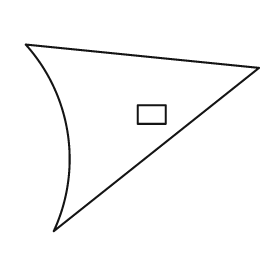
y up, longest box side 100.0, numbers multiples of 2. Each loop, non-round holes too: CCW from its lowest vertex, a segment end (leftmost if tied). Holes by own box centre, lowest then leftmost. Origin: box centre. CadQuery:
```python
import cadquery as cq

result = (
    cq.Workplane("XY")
    .moveTo(-38.0, -40.0)
    .lineTo(50.0, 30.0)
    .lineTo(-50.0, 40.0)
    .threePointArc((-32.0, 2.0), (-38.0, -40.0))
    .close()
    .moveTo(-2.0, 6.0)
    .lineTo(10.0, 6.0)
    .lineTo(10.0, 14.0)
    .lineTo(-2.0, 14.0)
    .close()
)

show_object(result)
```